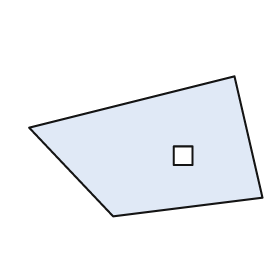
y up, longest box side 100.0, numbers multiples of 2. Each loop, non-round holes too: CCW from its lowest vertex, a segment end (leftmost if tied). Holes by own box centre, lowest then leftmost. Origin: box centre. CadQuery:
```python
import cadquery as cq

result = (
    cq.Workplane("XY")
    .moveTo(-14.0, -30.0)
    .lineTo(50.0, -22.0)
    .lineTo(38.0, 30.0)
    .lineTo(-50.0, 8.0)
    .close()
    .moveTo(12.0, -8.0)
    .lineTo(20.0, -8.0)
    .lineTo(20.0, 0.0)
    .lineTo(12.0, 0.0)
    .close()
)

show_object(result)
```